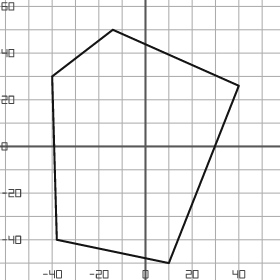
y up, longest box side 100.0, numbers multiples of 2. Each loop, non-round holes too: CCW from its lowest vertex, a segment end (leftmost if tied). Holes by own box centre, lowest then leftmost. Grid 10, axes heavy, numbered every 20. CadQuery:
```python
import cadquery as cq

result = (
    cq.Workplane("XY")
    .moveTo(10.0, -50.0)
    .lineTo(40.0, 26.0)
    .lineTo(-14.0, 50.0)
    .lineTo(-40.0, 30.0)
    .lineTo(-38.0, -40.0)
    .close()
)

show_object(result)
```